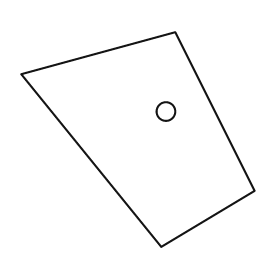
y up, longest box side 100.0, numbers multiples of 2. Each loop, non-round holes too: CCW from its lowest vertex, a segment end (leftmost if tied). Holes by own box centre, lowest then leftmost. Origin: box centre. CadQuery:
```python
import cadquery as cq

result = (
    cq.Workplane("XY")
    .moveTo(10.0, -46.0)
    .lineTo(50.0, -22.0)
    .lineTo(16.0, 46.0)
    .lineTo(-50.0, 28.0)
    .close()
    .moveTo(12.0, 12.0)
    .circle(4.0)
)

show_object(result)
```